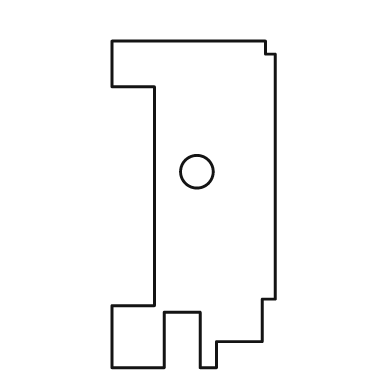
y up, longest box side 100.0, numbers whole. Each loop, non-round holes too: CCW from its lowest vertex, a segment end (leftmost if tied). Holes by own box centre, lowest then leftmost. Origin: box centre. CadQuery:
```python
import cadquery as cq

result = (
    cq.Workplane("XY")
    .moveTo(-25.0, -50.0)
    .lineTo(-9.0, -50.0)
    .lineTo(-9.0, -33.0)
    .lineTo(2.0, -33.0)
    .lineTo(2.0, -50.0)
    .lineTo(7.0, -50.0)
    .lineTo(7.0, -42.0)
    .lineTo(21.0, -42.0)
    .lineTo(21.0, -29.0)
    .lineTo(25.0, -29.0)
    .lineTo(25.0, 46.0)
    .lineTo(22.0, 46.0)
    .lineTo(22.0, 50.0)
    .lineTo(-25.0, 50.0)
    .lineTo(-25.0, 36.0)
    .lineTo(-12.0, 36.0)
    .lineTo(-12.0, -31.0)
    .lineTo(-25.0, -31.0)
    .close()
    .moveTo(1.0, 10.0)
    .circle(5.0)
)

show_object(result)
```